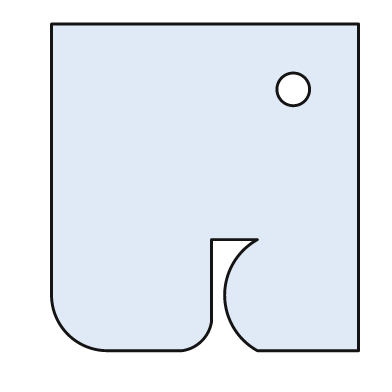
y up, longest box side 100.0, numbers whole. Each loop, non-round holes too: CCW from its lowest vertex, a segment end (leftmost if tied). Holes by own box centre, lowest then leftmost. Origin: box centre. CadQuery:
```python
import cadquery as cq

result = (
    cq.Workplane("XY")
    .moveTo(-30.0, -50.0)
    .lineTo(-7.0, -50.0)
    .threePointArc((-1.0, -47.0), (2.0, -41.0))
    .lineTo(2.0, -16.0)
    .lineTo(16.0, -16.0)
    .threePointArc((6.0, -33.0), (16.0, -50.0))
    .lineTo(47.0, -50.0)
    .lineTo(47.0, 50.0)
    .lineTo(-47.0, 50.0)
    .lineTo(-47.0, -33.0)
    .threePointArc((-42.0, -45.0), (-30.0, -50.0))
    .close()
    .moveTo(27.0, 30.0)
    .circle(5.0)
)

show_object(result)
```